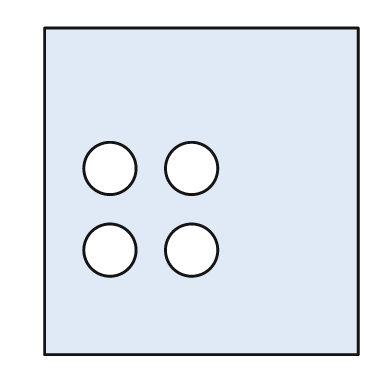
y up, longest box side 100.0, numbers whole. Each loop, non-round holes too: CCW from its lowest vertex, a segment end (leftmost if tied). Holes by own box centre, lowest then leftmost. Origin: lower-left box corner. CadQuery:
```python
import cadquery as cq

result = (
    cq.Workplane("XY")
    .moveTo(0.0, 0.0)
    .lineTo(96.0, 0.0)
    .lineTo(96.0, 100.0)
    .lineTo(0.0, 100.0)
    .close()
    .moveTo(20.0, 32.0)
    .circle(8.0)
    .moveTo(45.0, 32.0)
    .circle(8.0)
    .moveTo(20.0, 57.0)
    .circle(8.0)
    .moveTo(45.0, 57.0)
    .circle(8.0)
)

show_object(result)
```